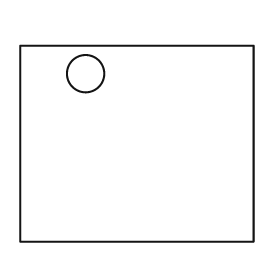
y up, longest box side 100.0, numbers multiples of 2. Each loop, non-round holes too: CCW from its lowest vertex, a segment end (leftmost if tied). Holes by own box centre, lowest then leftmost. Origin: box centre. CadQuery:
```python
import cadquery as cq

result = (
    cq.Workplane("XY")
    .moveTo(-50.0, -42.0)
    .lineTo(50.0, -42.0)
    .lineTo(50.0, 42.0)
    .lineTo(-50.0, 42.0)
    .close()
    .moveTo(-22.0, 30.0)
    .circle(8.0)
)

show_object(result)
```